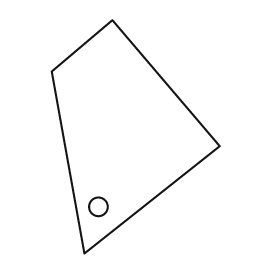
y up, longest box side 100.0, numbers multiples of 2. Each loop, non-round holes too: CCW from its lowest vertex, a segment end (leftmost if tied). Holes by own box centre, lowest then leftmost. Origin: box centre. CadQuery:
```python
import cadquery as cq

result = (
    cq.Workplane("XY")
    .moveTo(-22.0, -50.0)
    .lineTo(36.0, -4.0)
    .lineTo(-10.0, 50.0)
    .lineTo(-36.0, 28.0)
    .close()
    .moveTo(-16.0, -30.0)
    .circle(4.0)
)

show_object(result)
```